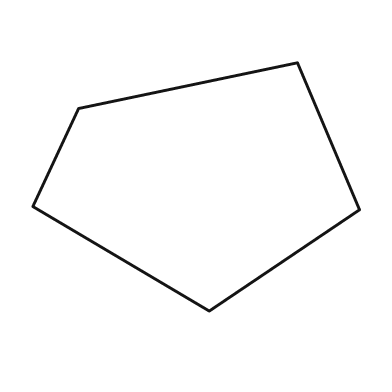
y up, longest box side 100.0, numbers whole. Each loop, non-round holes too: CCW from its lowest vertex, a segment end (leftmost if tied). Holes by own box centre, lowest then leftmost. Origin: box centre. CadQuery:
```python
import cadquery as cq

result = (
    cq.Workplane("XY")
    .moveTo(4.0, -38.0)
    .lineTo(50.0, -7.0)
    .lineTo(31.0, 38.0)
    .lineTo(-36.0, 24.0)
    .lineTo(-50.0, -6.0)
    .close()
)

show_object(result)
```